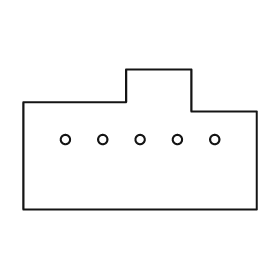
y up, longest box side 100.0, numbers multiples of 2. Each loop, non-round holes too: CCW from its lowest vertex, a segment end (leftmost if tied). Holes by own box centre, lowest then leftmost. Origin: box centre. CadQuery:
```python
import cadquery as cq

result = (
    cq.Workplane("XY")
    .moveTo(-50.0, -30.0)
    .lineTo(50.0, -30.0)
    .lineTo(50.0, 12.0)
    .lineTo(22.0, 12.0)
    .lineTo(22.0, 30.0)
    .lineTo(-6.0, 30.0)
    .lineTo(-6.0, 16.0)
    .lineTo(-50.0, 16.0)
    .close()
    .moveTo(-32.0, 0.0)
    .circle(2.0)
    .moveTo(-16.0, 0.0)
    .circle(2.0)
    .moveTo(0.0, 0.0)
    .circle(2.0)
    .moveTo(16.0, 0.0)
    .circle(2.0)
    .moveTo(32.0, 0.0)
    .circle(2.0)
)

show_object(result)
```